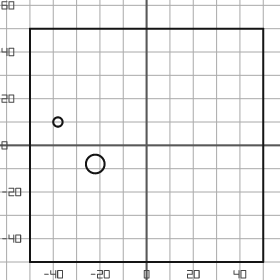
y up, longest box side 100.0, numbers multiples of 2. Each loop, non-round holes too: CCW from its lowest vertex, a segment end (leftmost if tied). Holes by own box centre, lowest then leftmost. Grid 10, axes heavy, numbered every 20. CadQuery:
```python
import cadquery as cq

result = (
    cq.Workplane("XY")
    .moveTo(-50.0, -50.0)
    .lineTo(50.0, -50.0)
    .lineTo(50.0, 50.0)
    .lineTo(-50.0, 50.0)
    .close()
    .moveTo(-22.0, -8.0)
    .circle(4.0)
    .moveTo(-38.0, 10.0)
    .circle(2.0)
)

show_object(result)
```